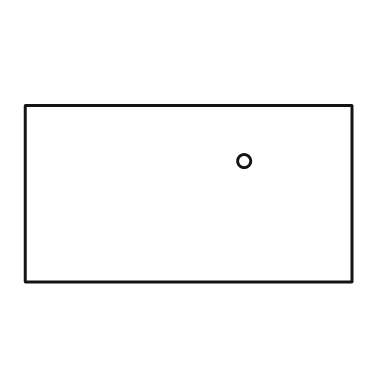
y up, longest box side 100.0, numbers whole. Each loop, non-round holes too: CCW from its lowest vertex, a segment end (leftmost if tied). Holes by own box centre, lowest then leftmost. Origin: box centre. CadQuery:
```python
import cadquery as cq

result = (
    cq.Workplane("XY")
    .moveTo(-50.0, -27.0)
    .lineTo(50.0, -27.0)
    .lineTo(50.0, 27.0)
    .lineTo(-50.0, 27.0)
    .close()
    .moveTo(17.0, 10.0)
    .circle(2.0)
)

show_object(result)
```